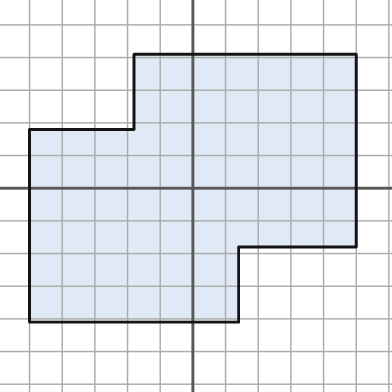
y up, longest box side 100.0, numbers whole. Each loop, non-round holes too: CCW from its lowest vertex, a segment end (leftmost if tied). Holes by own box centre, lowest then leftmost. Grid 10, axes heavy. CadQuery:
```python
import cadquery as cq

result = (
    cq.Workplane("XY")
    .moveTo(-50.0, -41.0)
    .lineTo(14.0, -41.0)
    .lineTo(14.0, -18.0)
    .lineTo(50.0, -18.0)
    .lineTo(50.0, 41.0)
    .lineTo(-18.0, 41.0)
    .lineTo(-18.0, 18.0)
    .lineTo(-50.0, 18.0)
    .close()
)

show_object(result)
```